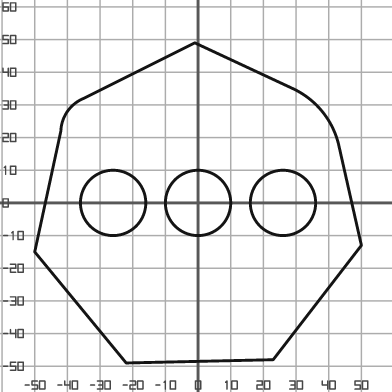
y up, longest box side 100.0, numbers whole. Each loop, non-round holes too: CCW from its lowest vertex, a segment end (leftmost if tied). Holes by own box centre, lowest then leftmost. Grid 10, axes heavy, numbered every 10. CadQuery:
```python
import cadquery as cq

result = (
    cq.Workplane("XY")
    .moveTo(-22.0, -49.0)
    .lineTo(23.0, -48.0)
    .lineTo(50.0, -13.0)
    .lineTo(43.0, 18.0)
    .threePointArc((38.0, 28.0), (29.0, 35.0))
    .lineTo(-1.0, 49.0)
    .lineTo(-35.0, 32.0)
    .threePointArc((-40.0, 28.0), (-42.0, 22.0))
    .lineTo(-50.0, -15.0)
    .close()
    .moveTo(-26.0, 0.0)
    .circle(10.0)
    .moveTo(0.0, 0.0)
    .circle(10.0)
    .moveTo(26.0, 0.0)
    .circle(10.0)
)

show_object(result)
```